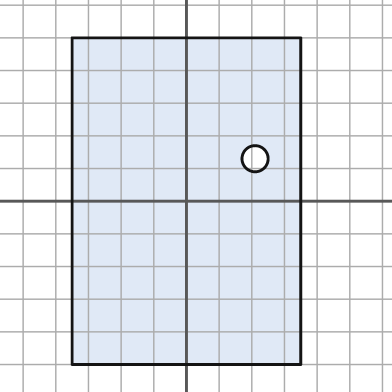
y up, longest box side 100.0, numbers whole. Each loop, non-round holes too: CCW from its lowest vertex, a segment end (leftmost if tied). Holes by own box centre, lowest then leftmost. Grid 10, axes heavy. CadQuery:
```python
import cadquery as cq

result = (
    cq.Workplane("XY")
    .moveTo(-35.0, -50.0)
    .lineTo(35.0, -50.0)
    .lineTo(35.0, 50.0)
    .lineTo(-35.0, 50.0)
    .close()
    .moveTo(21.0, 13.0)
    .circle(4.0)
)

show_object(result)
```